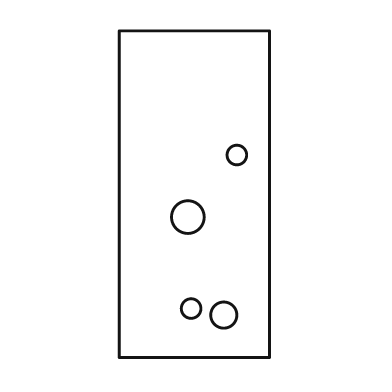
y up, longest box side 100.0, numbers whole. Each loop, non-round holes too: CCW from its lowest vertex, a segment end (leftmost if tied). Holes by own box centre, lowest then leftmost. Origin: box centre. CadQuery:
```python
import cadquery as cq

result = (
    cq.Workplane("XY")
    .moveTo(-23.0, -50.0)
    .lineTo(23.0, -50.0)
    .lineTo(23.0, 50.0)
    .lineTo(-23.0, 50.0)
    .close()
    .moveTo(9.0, -37.0)
    .circle(4.0)
    .moveTo(-1.0, -35.0)
    .circle(3.0)
    .moveTo(-2.0, -7.0)
    .circle(5.0)
    .moveTo(13.0, 12.0)
    .circle(3.0)
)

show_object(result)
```